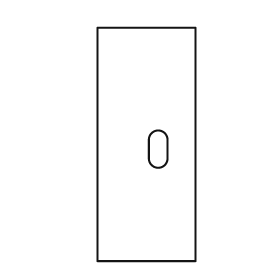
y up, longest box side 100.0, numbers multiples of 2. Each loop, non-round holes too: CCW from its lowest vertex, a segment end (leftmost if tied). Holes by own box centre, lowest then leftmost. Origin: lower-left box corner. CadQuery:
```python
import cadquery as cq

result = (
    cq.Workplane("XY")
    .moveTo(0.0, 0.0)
    .lineTo(42.0, 0.0)
    .lineTo(42.0, 100.0)
    .lineTo(0.0, 100.0)
    .close()
    .moveTo(22.0, 44.0)
    .threePointArc((26.0, 40.0), (30.0, 44.0))
    .lineTo(30.0, 52.0)
    .threePointArc((26.0, 56.0), (22.0, 52.0))
    .close()
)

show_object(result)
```